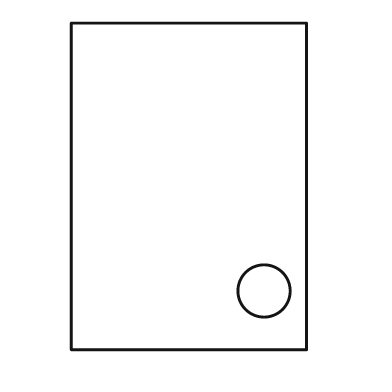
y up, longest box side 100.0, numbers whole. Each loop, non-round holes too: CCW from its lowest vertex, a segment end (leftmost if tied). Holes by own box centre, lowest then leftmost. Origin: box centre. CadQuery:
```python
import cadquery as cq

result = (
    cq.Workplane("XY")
    .moveTo(-36.0, -50.0)
    .lineTo(36.0, -50.0)
    .lineTo(36.0, 50.0)
    .lineTo(-36.0, 50.0)
    .close()
    .moveTo(23.0, -32.0)
    .circle(8.0)
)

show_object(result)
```